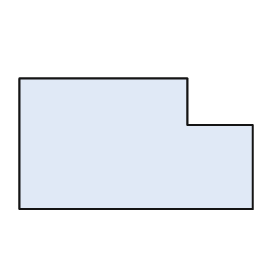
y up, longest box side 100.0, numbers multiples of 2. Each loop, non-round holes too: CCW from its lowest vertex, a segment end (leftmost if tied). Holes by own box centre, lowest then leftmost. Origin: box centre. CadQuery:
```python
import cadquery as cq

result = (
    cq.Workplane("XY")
    .moveTo(-50.0, -28.0)
    .lineTo(50.0, -28.0)
    .lineTo(50.0, 8.0)
    .lineTo(22.0, 8.0)
    .lineTo(22.0, 28.0)
    .lineTo(-50.0, 28.0)
    .close()
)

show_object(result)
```